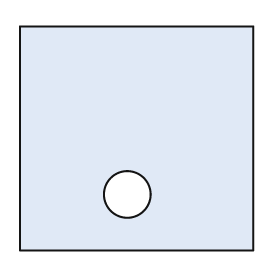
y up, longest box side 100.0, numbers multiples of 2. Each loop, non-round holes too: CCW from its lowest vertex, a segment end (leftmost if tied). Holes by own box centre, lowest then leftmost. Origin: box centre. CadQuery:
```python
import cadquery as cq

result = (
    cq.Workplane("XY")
    .moveTo(-50.0, -48.0)
    .lineTo(50.0, -48.0)
    .lineTo(50.0, 48.0)
    .lineTo(-50.0, 48.0)
    .close()
    .moveTo(-4.0, -24.0)
    .circle(10.0)
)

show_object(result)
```